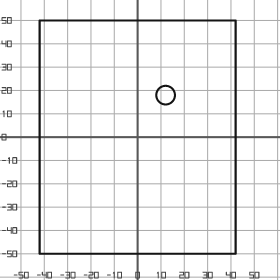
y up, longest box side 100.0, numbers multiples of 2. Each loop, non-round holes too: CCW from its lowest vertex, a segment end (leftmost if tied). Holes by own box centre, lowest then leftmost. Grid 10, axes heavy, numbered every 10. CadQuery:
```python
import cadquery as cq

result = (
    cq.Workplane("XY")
    .moveTo(-42.0, -50.0)
    .lineTo(42.0, -50.0)
    .lineTo(42.0, 50.0)
    .lineTo(-42.0, 50.0)
    .close()
    .moveTo(12.0, 18.0)
    .circle(4.0)
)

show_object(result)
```